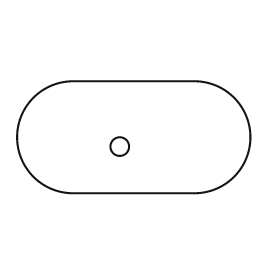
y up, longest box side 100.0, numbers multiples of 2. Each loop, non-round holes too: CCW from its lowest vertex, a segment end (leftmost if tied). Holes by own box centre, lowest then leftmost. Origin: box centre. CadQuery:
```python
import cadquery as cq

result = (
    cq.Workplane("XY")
    .moveTo(-26.0, -24.0)
    .lineTo(26.0, -24.0)
    .threePointArc((50.0, 0.0), (26.0, 24.0))
    .lineTo(-26.0, 24.0)
    .threePointArc((-50.0, 0.0), (-26.0, -24.0))
    .close()
    .moveTo(-6.0, -4.0)
    .circle(4.0)
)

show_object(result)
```